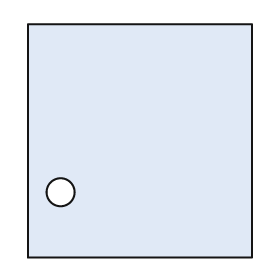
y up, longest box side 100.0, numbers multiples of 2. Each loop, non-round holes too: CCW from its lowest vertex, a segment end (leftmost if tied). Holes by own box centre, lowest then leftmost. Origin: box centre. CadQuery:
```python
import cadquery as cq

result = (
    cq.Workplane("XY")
    .moveTo(-48.0, -50.0)
    .lineTo(48.0, -50.0)
    .lineTo(48.0, 50.0)
    .lineTo(-48.0, 50.0)
    .close()
    .moveTo(-34.0, -22.0)
    .circle(6.0)
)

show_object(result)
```